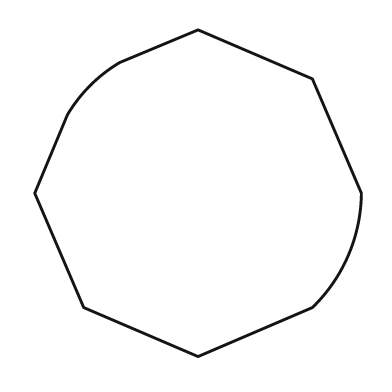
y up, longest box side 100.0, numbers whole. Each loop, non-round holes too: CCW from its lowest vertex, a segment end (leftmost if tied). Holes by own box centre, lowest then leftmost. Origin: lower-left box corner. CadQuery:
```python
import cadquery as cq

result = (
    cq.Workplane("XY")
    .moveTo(50.0, 0.0)
    .lineTo(85.0, 15.0)
    .threePointArc((96.0, 31.0), (100.0, 50.0))
    .lineTo(85.0, 85.0)
    .lineTo(50.0, 100.0)
    .lineTo(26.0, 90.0)
    .threePointArc((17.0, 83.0), (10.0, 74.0))
    .lineTo(0.0, 50.0)
    .lineTo(15.0, 15.0)
    .close()
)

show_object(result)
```